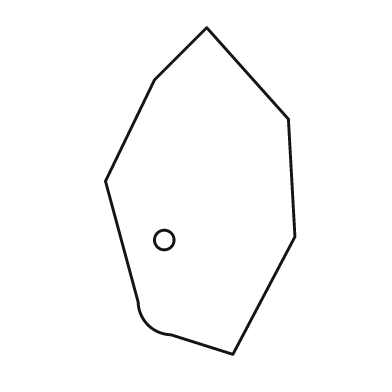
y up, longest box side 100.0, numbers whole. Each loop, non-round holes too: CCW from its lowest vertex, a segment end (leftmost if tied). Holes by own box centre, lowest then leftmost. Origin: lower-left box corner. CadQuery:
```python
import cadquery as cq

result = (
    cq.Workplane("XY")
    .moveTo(39.0, 0.0)
    .lineTo(58.0, 36.0)
    .lineTo(56.0, 72.0)
    .lineTo(31.0, 100.0)
    .lineTo(15.0, 84.0)
    .lineTo(0.0, 53.0)
    .lineTo(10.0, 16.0)
    .threePointArc((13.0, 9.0), (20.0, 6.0))
    .close()
    .moveTo(18.0, 35.0)
    .circle(3.0)
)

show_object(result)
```